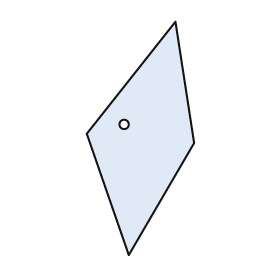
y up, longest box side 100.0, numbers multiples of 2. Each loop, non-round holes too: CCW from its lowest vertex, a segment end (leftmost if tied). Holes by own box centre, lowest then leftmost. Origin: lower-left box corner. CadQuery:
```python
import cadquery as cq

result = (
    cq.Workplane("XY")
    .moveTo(18.0, 0.0)
    .lineTo(46.0, 48.0)
    .lineTo(38.0, 100.0)
    .lineTo(0.0, 52.0)
    .close()
    .moveTo(16.0, 56.0)
    .circle(2.0)
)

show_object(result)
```